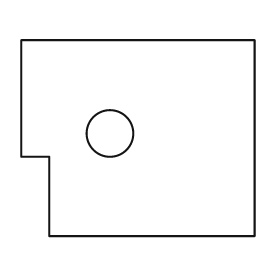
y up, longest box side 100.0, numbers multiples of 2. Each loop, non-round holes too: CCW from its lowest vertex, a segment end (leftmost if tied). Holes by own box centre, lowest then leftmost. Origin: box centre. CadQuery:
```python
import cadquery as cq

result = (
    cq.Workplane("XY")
    .moveTo(-38.0, -42.0)
    .lineTo(50.0, -42.0)
    .lineTo(50.0, 42.0)
    .lineTo(-50.0, 42.0)
    .lineTo(-50.0, -8.0)
    .lineTo(-38.0, -8.0)
    .close()
    .moveTo(-12.0, 2.0)
    .circle(10.0)
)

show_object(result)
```